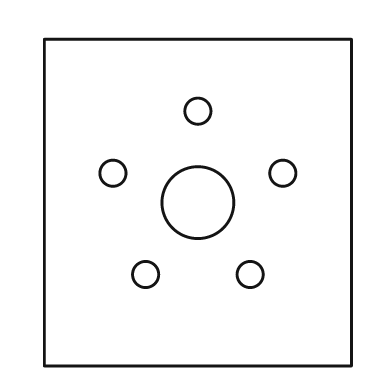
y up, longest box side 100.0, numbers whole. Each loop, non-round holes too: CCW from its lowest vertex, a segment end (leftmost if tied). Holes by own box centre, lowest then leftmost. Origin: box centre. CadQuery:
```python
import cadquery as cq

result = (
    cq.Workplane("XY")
    .moveTo(-47.0, -50.0)
    .lineTo(47.0, -50.0)
    .lineTo(47.0, 50.0)
    .lineTo(-47.0, 50.0)
    .close()
    .moveTo(-16.0, -22.0)
    .circle(4.0)
    .moveTo(16.0, -22.0)
    .circle(4.0)
    .moveTo(0.0, 0.0)
    .circle(11.0)
    .moveTo(-26.0, 9.0)
    .circle(4.0)
    .moveTo(26.0, 9.0)
    .circle(4.0)
    .moveTo(0.0, 28.0)
    .circle(4.0)
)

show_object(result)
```